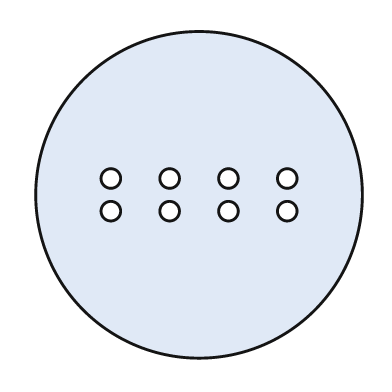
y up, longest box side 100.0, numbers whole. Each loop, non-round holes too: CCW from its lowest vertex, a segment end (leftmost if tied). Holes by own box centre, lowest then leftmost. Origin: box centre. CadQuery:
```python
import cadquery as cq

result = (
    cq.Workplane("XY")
    .moveTo(0.0, 0.0)
    .circle(50.0)
    .moveTo(-27.0, -5.0)
    .circle(3.0)
    .moveTo(-9.0, -5.0)
    .circle(3.0)
    .moveTo(9.0, -5.0)
    .circle(3.0)
    .moveTo(27.0, -5.0)
    .circle(3.0)
    .moveTo(-27.0, 5.0)
    .circle(3.0)
    .moveTo(-9.0, 5.0)
    .circle(3.0)
    .moveTo(9.0, 5.0)
    .circle(3.0)
    .moveTo(27.0, 5.0)
    .circle(3.0)
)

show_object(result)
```